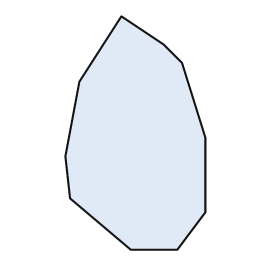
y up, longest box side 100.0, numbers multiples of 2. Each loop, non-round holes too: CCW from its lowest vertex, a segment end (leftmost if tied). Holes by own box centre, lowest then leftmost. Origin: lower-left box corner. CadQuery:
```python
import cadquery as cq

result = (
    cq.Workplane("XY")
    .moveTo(28.0, 0.0)
    .lineTo(48.0, 0.0)
    .lineTo(60.0, 16.0)
    .lineTo(60.0, 48.0)
    .lineTo(50.0, 80.0)
    .lineTo(42.0, 88.0)
    .lineTo(24.0, 100.0)
    .lineTo(6.0, 72.0)
    .lineTo(0.0, 40.0)
    .lineTo(2.0, 22.0)
    .close()
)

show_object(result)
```